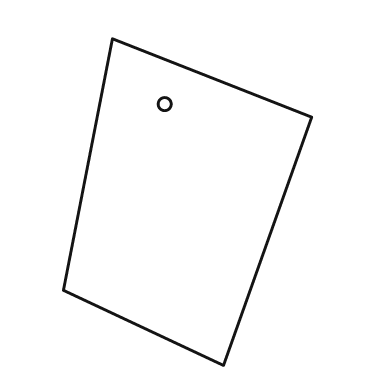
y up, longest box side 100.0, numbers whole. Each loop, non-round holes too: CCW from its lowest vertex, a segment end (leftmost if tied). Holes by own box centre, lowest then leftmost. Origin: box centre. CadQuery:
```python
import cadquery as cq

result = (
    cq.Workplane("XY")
    .moveTo(11.0, -50.0)
    .lineTo(38.0, 26.0)
    .lineTo(-23.0, 50.0)
    .lineTo(-38.0, -27.0)
    .close()
    .moveTo(-7.0, 30.0)
    .circle(2.0)
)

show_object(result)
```